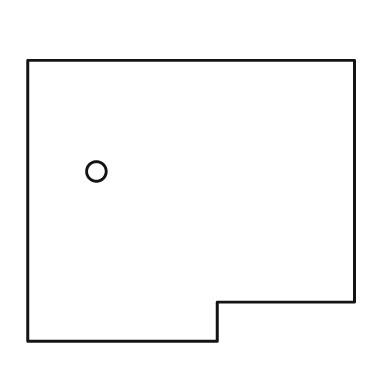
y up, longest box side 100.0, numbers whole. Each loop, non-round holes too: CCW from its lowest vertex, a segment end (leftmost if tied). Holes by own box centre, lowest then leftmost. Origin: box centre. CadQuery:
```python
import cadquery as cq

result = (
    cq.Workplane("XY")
    .moveTo(-50.0, -43.0)
    .lineTo(8.0, -43.0)
    .lineTo(8.0, -31.0)
    .lineTo(50.0, -31.0)
    .lineTo(50.0, 43.0)
    .lineTo(-50.0, 43.0)
    .close()
    .moveTo(-29.0, 9.0)
    .circle(3.0)
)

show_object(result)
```